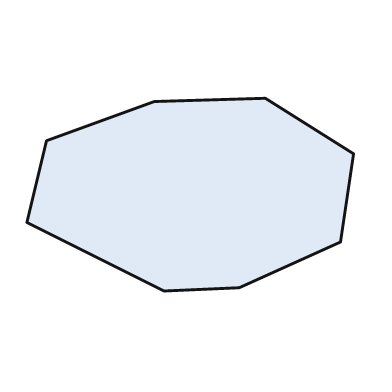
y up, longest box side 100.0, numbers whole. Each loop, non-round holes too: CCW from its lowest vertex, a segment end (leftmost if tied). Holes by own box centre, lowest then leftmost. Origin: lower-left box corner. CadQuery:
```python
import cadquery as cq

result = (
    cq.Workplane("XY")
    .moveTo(42.0, 0.0)
    .lineTo(65.0, 1.0)
    .lineTo(96.0, 15.0)
    .lineTo(100.0, 42.0)
    .lineTo(73.0, 59.0)
    .lineTo(39.0, 58.0)
    .lineTo(6.0, 46.0)
    .lineTo(0.0, 21.0)
    .close()
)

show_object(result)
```